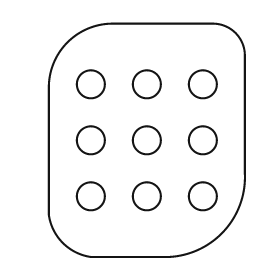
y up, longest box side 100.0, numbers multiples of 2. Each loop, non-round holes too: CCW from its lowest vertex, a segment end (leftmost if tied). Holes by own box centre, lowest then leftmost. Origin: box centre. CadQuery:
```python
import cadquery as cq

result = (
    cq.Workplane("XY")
    .moveTo(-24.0, -50.0)
    .lineTo(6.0, -50.0)
    .threePointArc((32.0, -40.0), (42.0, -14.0))
    .lineTo(42.0, 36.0)
    .threePointArc((38.0, 46.0), (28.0, 50.0))
    .lineTo(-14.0, 50.0)
    .threePointArc((-34.0, 42.0), (-42.0, 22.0))
    .lineTo(-42.0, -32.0)
    .threePointArc((-36.0, -44.0), (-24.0, -50.0))
    .close()
    .moveTo(-24.0, -24.0)
    .circle(6.0)
    .moveTo(0.0, -24.0)
    .circle(6.0)
    .moveTo(24.0, -24.0)
    .circle(6.0)
    .moveTo(-24.0, 0.0)
    .circle(6.0)
    .moveTo(0.0, 0.0)
    .circle(6.0)
    .moveTo(24.0, 0.0)
    .circle(6.0)
    .moveTo(-24.0, 24.0)
    .circle(6.0)
    .moveTo(0.0, 24.0)
    .circle(6.0)
    .moveTo(24.0, 24.0)
    .circle(6.0)
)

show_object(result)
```